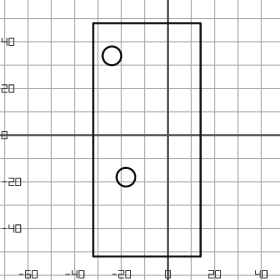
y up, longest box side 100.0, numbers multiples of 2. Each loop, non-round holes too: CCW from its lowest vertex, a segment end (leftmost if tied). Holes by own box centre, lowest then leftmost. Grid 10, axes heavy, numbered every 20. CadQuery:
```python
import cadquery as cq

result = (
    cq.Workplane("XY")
    .moveTo(-32.0, -52.0)
    .lineTo(14.0, -52.0)
    .lineTo(14.0, 48.0)
    .lineTo(-32.0, 48.0)
    .close()
    .moveTo(-18.0, -18.0)
    .circle(4.0)
    .moveTo(-24.0, 34.0)
    .circle(4.0)
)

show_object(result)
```